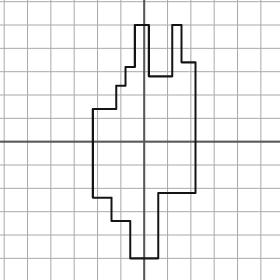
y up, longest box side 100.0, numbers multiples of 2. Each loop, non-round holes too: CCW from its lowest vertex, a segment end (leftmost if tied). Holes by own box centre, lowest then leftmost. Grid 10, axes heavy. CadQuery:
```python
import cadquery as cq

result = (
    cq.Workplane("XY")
    .moveTo(-6.0, -50.0)
    .lineTo(6.0, -50.0)
    .lineTo(6.0, -22.0)
    .lineTo(22.0, -22.0)
    .lineTo(22.0, 34.0)
    .lineTo(16.0, 34.0)
    .lineTo(16.0, 50.0)
    .lineTo(12.0, 50.0)
    .lineTo(12.0, 28.0)
    .lineTo(2.0, 28.0)
    .lineTo(2.0, 50.0)
    .lineTo(-4.0, 50.0)
    .lineTo(-4.0, 32.0)
    .lineTo(-8.0, 32.0)
    .lineTo(-8.0, 24.0)
    .lineTo(-12.0, 24.0)
    .lineTo(-12.0, 14.0)
    .lineTo(-22.0, 14.0)
    .lineTo(-22.0, -24.0)
    .lineTo(-14.0, -24.0)
    .lineTo(-14.0, -34.0)
    .lineTo(-6.0, -34.0)
    .close()
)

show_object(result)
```